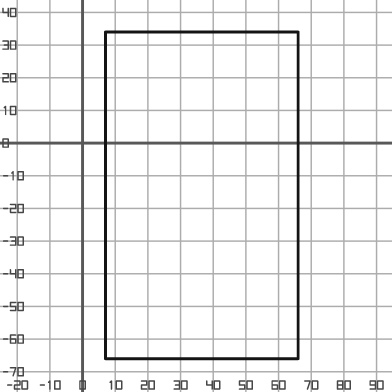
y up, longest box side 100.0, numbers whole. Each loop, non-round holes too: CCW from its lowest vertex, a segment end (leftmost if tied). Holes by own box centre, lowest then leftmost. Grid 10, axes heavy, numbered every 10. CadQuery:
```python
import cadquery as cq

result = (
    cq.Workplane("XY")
    .moveTo(7.0, -66.0)
    .lineTo(66.0, -66.0)
    .lineTo(66.0, 34.0)
    .lineTo(7.0, 34.0)
    .close()
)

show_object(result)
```